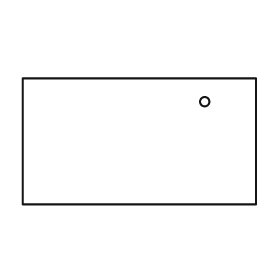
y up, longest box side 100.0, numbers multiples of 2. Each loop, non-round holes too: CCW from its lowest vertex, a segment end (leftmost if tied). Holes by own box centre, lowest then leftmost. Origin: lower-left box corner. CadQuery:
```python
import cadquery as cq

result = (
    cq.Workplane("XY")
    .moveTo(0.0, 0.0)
    .lineTo(100.0, 0.0)
    .lineTo(100.0, 54.0)
    .lineTo(0.0, 54.0)
    .close()
    .moveTo(78.0, 44.0)
    .circle(2.0)
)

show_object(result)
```